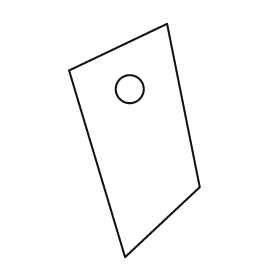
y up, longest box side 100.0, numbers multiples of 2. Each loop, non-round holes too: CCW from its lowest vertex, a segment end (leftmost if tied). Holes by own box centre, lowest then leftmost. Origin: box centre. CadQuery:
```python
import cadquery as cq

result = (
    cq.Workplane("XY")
    .moveTo(-4.0, -50.0)
    .lineTo(28.0, -20.0)
    .lineTo(14.0, 50.0)
    .lineTo(-28.0, 30.0)
    .close()
    .moveTo(-2.0, 22.0)
    .circle(6.0)
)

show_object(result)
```